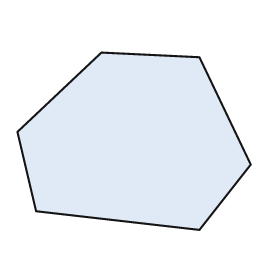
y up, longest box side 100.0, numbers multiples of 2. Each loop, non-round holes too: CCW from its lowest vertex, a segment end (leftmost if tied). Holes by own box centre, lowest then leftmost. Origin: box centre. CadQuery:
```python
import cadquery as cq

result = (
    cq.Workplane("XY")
    .moveTo(28.0, -38.0)
    .lineTo(50.0, -10.0)
    .lineTo(28.0, 36.0)
    .lineTo(-14.0, 38.0)
    .lineTo(-50.0, 4.0)
    .lineTo(-42.0, -30.0)
    .close()
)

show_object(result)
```